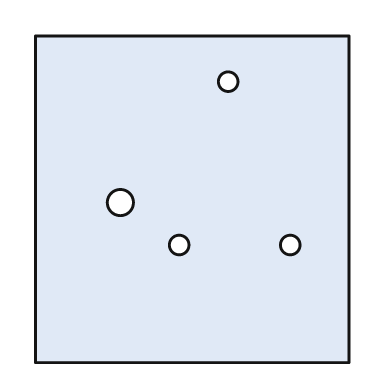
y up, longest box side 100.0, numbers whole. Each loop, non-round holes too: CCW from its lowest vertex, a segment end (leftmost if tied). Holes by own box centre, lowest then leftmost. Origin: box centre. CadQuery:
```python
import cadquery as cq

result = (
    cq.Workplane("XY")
    .moveTo(-48.0, -50.0)
    .lineTo(48.0, -50.0)
    .lineTo(48.0, 50.0)
    .lineTo(-48.0, 50.0)
    .close()
    .moveTo(-4.0, -14.0)
    .circle(3.0)
    .moveTo(30.0, -14.0)
    .circle(3.0)
    .moveTo(-22.0, -1.0)
    .circle(4.0)
    .moveTo(11.0, 36.0)
    .circle(3.0)
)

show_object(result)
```